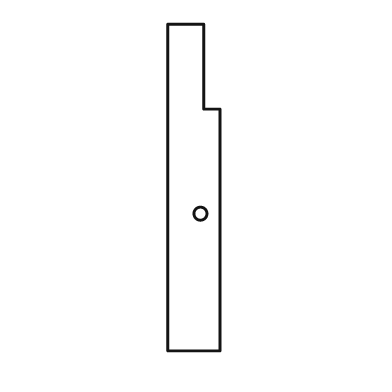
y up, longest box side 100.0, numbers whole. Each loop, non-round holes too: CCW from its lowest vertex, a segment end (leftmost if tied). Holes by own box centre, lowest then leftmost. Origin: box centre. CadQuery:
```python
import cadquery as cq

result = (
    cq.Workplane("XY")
    .moveTo(-8.0, -50.0)
    .lineTo(8.0, -50.0)
    .lineTo(8.0, 24.0)
    .lineTo(3.0, 24.0)
    .lineTo(3.0, 50.0)
    .lineTo(-8.0, 50.0)
    .close()
    .moveTo(2.0, -8.0)
    .circle(2.0)
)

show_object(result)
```